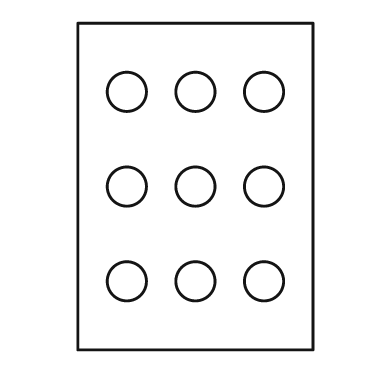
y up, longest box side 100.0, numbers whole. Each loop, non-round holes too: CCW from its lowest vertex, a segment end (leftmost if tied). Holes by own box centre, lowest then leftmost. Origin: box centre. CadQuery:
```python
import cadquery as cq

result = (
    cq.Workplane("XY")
    .moveTo(-36.0, -50.0)
    .lineTo(36.0, -50.0)
    .lineTo(36.0, 50.0)
    .lineTo(-36.0, 50.0)
    .close()
    .moveTo(-21.0, -29.0)
    .circle(6.0)
    .moveTo(0.0, -29.0)
    .circle(6.0)
    .moveTo(21.0, -29.0)
    .circle(6.0)
    .moveTo(-21.0, 0.0)
    .circle(6.0)
    .moveTo(0.0, 0.0)
    .circle(6.0)
    .moveTo(21.0, 0.0)
    .circle(6.0)
    .moveTo(-21.0, 29.0)
    .circle(6.0)
    .moveTo(0.0, 29.0)
    .circle(6.0)
    .moveTo(21.0, 29.0)
    .circle(6.0)
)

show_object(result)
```